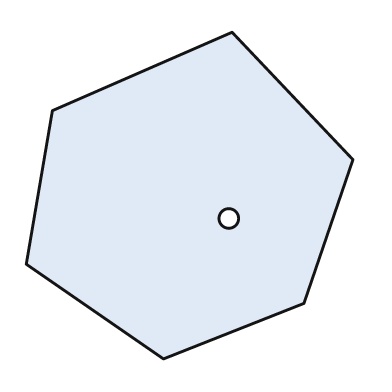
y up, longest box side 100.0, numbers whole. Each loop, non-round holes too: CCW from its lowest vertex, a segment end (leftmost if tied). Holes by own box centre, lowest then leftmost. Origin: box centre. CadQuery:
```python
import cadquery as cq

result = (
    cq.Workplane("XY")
    .moveTo(-8.0, -50.0)
    .lineTo(35.0, -33.0)
    .lineTo(50.0, 11.0)
    .lineTo(13.0, 50.0)
    .lineTo(-42.0, 26.0)
    .lineTo(-50.0, -21.0)
    .close()
    .moveTo(12.0, -7.0)
    .circle(3.0)
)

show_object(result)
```